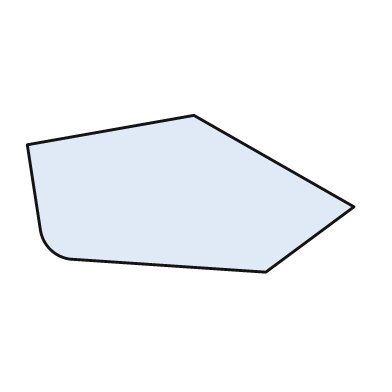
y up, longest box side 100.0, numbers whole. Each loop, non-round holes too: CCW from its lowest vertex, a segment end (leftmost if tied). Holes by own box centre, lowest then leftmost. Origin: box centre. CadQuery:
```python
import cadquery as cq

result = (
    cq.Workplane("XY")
    .moveTo(23.0, -24.0)
    .lineTo(50.0, -4.0)
    .lineTo(1.0, 24.0)
    .lineTo(-50.0, 15.0)
    .lineTo(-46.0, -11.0)
    .threePointArc((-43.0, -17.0), (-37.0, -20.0))
    .close()
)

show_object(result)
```